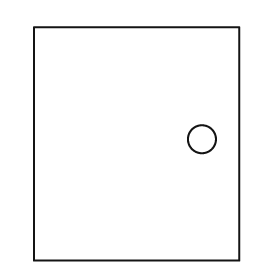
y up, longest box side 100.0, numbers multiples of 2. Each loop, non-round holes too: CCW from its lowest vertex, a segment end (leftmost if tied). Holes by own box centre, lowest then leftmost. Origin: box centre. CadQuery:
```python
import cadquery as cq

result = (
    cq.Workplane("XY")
    .moveTo(-44.0, -50.0)
    .lineTo(44.0, -50.0)
    .lineTo(44.0, 50.0)
    .lineTo(-44.0, 50.0)
    .close()
    .moveTo(28.0, 2.0)
    .circle(6.0)
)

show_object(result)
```